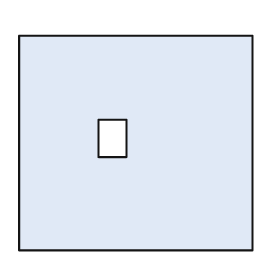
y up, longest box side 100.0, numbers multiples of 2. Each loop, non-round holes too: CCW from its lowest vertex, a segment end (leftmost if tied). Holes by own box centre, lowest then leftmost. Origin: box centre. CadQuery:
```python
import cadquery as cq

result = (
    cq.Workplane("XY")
    .moveTo(-50.0, -46.0)
    .lineTo(50.0, -46.0)
    .lineTo(50.0, 46.0)
    .lineTo(-50.0, 46.0)
    .close()
    .moveTo(-16.0, -6.0)
    .lineTo(-4.0, -6.0)
    .lineTo(-4.0, 10.0)
    .lineTo(-16.0, 10.0)
    .close()
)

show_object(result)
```